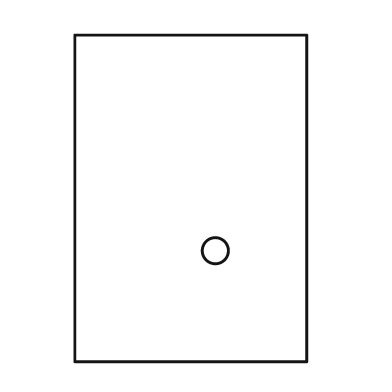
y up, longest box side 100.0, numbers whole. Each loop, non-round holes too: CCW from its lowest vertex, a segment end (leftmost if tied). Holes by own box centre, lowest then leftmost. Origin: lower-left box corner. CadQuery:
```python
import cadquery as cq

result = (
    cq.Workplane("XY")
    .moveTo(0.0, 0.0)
    .lineTo(71.0, 0.0)
    .lineTo(71.0, 100.0)
    .lineTo(0.0, 100.0)
    .close()
    .moveTo(43.0, 34.0)
    .circle(4.0)
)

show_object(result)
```